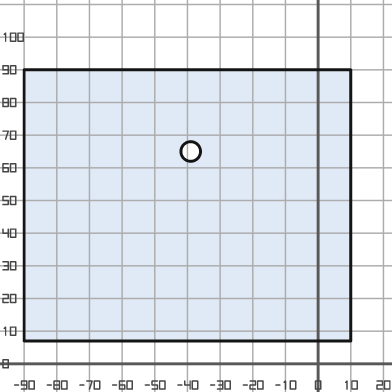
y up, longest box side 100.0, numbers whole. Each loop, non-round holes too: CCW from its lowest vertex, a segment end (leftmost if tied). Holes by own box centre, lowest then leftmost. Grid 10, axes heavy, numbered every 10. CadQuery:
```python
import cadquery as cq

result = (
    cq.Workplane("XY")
    .moveTo(-90.0, 7.0)
    .lineTo(10.0, 7.0)
    .lineTo(10.0, 90.0)
    .lineTo(-90.0, 90.0)
    .close()
    .moveTo(-39.0, 65.0)
    .circle(3.0)
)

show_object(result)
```